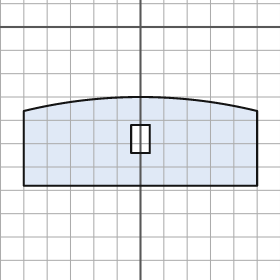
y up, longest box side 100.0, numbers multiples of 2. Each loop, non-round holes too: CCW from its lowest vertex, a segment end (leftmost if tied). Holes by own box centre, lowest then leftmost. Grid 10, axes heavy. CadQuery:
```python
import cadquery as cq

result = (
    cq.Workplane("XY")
    .moveTo(-50.0, -68.0)
    .lineTo(50.0, -68.0)
    .lineTo(50.0, -36.0)
    .threePointArc((0.0, -30.0), (-50.0, -36.0))
    .close()
    .moveTo(-4.0, -54.0)
    .lineTo(4.0, -54.0)
    .lineTo(4.0, -42.0)
    .lineTo(-4.0, -42.0)
    .close()
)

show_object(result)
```